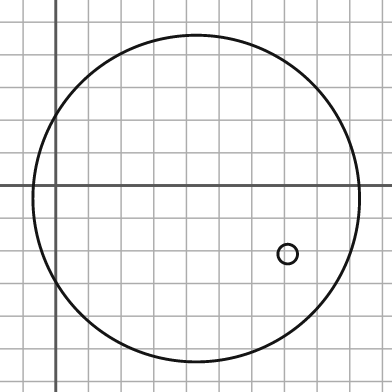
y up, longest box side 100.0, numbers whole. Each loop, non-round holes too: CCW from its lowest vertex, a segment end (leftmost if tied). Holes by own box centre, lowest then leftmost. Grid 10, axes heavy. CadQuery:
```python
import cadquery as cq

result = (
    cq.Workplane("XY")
    .moveTo(43.0, -4.0)
    .circle(50.0)
    .moveTo(71.0, -21.0)
    .circle(3.0)
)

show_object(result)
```